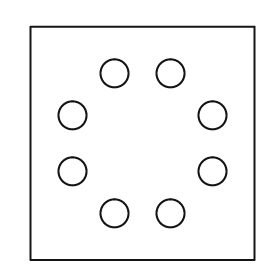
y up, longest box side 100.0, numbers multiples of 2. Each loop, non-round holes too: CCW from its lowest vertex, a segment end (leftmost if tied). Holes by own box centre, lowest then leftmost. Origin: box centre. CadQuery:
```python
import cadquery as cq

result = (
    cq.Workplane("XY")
    .moveTo(-48.0, -50.0)
    .lineTo(48.0, -50.0)
    .lineTo(48.0, 50.0)
    .lineTo(-48.0, 50.0)
    .close()
    .moveTo(-12.0, -30.0)
    .circle(6.0)
    .moveTo(12.0, -30.0)
    .circle(6.0)
    .moveTo(-30.0, -12.0)
    .circle(6.0)
    .moveTo(30.0, -12.0)
    .circle(6.0)
    .moveTo(-30.0, 12.0)
    .circle(6.0)
    .moveTo(30.0, 12.0)
    .circle(6.0)
    .moveTo(-12.0, 30.0)
    .circle(6.0)
    .moveTo(12.0, 30.0)
    .circle(6.0)
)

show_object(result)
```